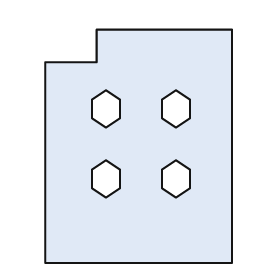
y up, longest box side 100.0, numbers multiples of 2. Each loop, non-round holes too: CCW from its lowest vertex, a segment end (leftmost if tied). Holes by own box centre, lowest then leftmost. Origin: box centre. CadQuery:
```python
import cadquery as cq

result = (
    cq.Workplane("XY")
    .moveTo(-40.0, -50.0)
    .lineTo(40.0, -50.0)
    .lineTo(40.0, 50.0)
    .lineTo(-18.0, 50.0)
    .lineTo(-18.0, 36.0)
    .lineTo(-40.0, 36.0)
    .close()
    .moveTo(-14.0, -22.0)
    .lineTo(-8.0, -18.0)
    .lineTo(-8.0, -10.0)
    .lineTo(-14.0, -6.0)
    .lineTo(-20.0, -10.0)
    .lineTo(-20.0, -18.0)
    .close()
    .moveTo(16.0, -22.0)
    .lineTo(22.0, -18.0)
    .lineTo(22.0, -10.0)
    .lineTo(16.0, -6.0)
    .lineTo(10.0, -10.0)
    .lineTo(10.0, -18.0)
    .close()
    .moveTo(-14.0, 8.0)
    .lineTo(-8.0, 12.0)
    .lineTo(-8.0, 20.0)
    .lineTo(-14.0, 24.0)
    .lineTo(-20.0, 20.0)
    .lineTo(-20.0, 12.0)
    .close()
    .moveTo(16.0, 8.0)
    .lineTo(22.0, 12.0)
    .lineTo(22.0, 20.0)
    .lineTo(16.0, 24.0)
    .lineTo(10.0, 20.0)
    .lineTo(10.0, 12.0)
    .close()
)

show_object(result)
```